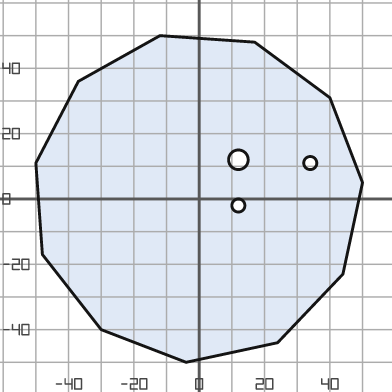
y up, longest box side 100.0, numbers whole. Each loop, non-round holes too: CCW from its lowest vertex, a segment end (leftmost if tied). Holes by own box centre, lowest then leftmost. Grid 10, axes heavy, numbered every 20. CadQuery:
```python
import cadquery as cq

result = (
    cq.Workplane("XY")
    .moveTo(-4.0, -50.0)
    .lineTo(24.0, -44.0)
    .lineTo(44.0, -23.0)
    .lineTo(50.0, 5.0)
    .lineTo(40.0, 31.0)
    .lineTo(17.0, 48.0)
    .lineTo(-12.0, 50.0)
    .lineTo(-37.0, 36.0)
    .lineTo(-50.0, 11.0)
    .lineTo(-48.0, -17.0)
    .lineTo(-30.0, -40.0)
    .close()
    .moveTo(12.0, -2.0)
    .circle(2.0)
    .moveTo(34.0, 11.0)
    .circle(2.0)
    .moveTo(12.0, 12.0)
    .circle(3.0)
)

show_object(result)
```